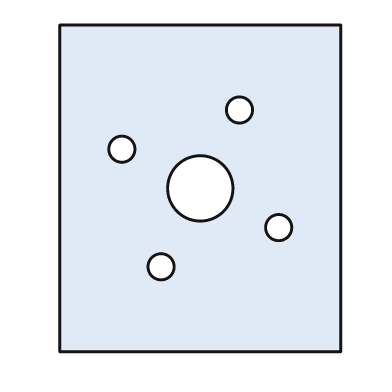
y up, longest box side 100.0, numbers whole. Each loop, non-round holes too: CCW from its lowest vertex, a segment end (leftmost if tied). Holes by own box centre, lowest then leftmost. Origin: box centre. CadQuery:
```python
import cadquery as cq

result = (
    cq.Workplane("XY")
    .moveTo(-43.0, -50.0)
    .lineTo(43.0, -50.0)
    .lineTo(43.0, 50.0)
    .lineTo(-43.0, 50.0)
    .close()
    .moveTo(-12.0, -24.0)
    .circle(4.0)
    .moveTo(24.0, -12.0)
    .circle(4.0)
    .moveTo(0.0, 0.0)
    .circle(10.0)
    .moveTo(-24.0, 12.0)
    .circle(4.0)
    .moveTo(12.0, 24.0)
    .circle(4.0)
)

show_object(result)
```